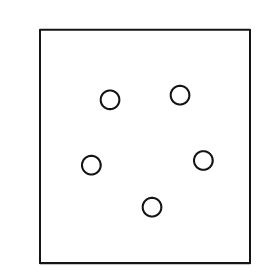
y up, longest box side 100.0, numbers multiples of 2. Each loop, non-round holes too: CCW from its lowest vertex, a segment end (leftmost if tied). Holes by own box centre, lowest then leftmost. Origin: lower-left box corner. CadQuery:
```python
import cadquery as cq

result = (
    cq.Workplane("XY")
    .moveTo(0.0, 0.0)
    .lineTo(90.0, 0.0)
    .lineTo(90.0, 100.0)
    .lineTo(0.0, 100.0)
    .close()
    .moveTo(48.0, 24.0)
    .circle(4.0)
    .moveTo(22.0, 42.0)
    .circle(4.0)
    .moveTo(70.0, 44.0)
    .circle(4.0)
    .moveTo(30.0, 70.0)
    .circle(4.0)
    .moveTo(60.0, 72.0)
    .circle(4.0)
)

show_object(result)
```